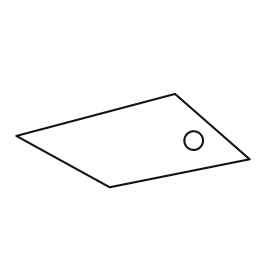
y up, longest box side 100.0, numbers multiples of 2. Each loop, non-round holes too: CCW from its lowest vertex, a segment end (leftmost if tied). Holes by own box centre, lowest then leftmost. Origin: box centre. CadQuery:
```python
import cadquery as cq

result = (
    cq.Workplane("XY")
    .moveTo(-10.0, -20.0)
    .lineTo(50.0, -8.0)
    .lineTo(18.0, 20.0)
    .lineTo(-50.0, 2.0)
    .close()
    .moveTo(26.0, 0.0)
    .circle(4.0)
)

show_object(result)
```